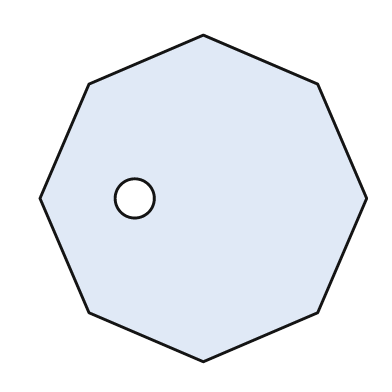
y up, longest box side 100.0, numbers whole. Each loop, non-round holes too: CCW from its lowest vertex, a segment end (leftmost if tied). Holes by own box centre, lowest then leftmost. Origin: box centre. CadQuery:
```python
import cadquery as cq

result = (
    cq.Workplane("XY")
    .moveTo(0.0, -50.0)
    .lineTo(35.0, -35.0)
    .lineTo(50.0, 0.0)
    .lineTo(35.0, 35.0)
    .lineTo(0.0, 50.0)
    .lineTo(-35.0, 35.0)
    .lineTo(-50.0, 0.0)
    .lineTo(-35.0, -35.0)
    .close()
    .moveTo(-21.0, 0.0)
    .circle(6.0)
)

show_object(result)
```